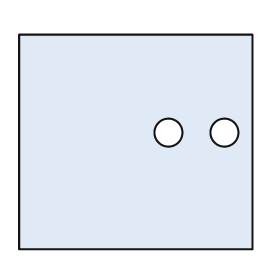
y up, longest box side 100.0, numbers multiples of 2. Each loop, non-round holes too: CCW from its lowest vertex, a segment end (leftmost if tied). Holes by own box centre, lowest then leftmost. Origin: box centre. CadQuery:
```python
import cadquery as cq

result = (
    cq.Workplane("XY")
    .moveTo(-50.0, -46.0)
    .lineTo(50.0, -46.0)
    .lineTo(50.0, 46.0)
    .lineTo(-50.0, 46.0)
    .close()
    .moveTo(14.0, 4.0)
    .circle(6.0)
    .moveTo(38.0, 4.0)
    .circle(6.0)
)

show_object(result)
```